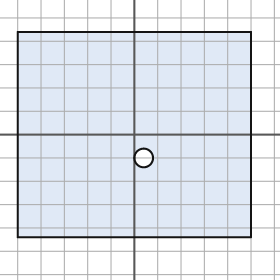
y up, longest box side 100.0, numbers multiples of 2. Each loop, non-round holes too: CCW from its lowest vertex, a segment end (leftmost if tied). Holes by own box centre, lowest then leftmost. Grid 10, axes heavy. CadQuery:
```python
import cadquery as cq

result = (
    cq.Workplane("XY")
    .moveTo(-50.0, -44.0)
    .lineTo(50.0, -44.0)
    .lineTo(50.0, 44.0)
    .lineTo(-50.0, 44.0)
    .close()
    .moveTo(4.0, -10.0)
    .circle(4.0)
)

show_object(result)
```